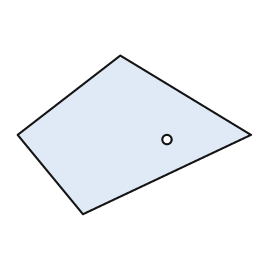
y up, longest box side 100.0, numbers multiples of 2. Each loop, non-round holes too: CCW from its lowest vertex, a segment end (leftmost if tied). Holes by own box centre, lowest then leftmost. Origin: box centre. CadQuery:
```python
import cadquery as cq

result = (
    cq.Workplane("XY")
    .moveTo(-22.0, -34.0)
    .lineTo(50.0, 0.0)
    .lineTo(-6.0, 34.0)
    .lineTo(-50.0, 0.0)
    .close()
    .moveTo(14.0, -2.0)
    .circle(2.0)
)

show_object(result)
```